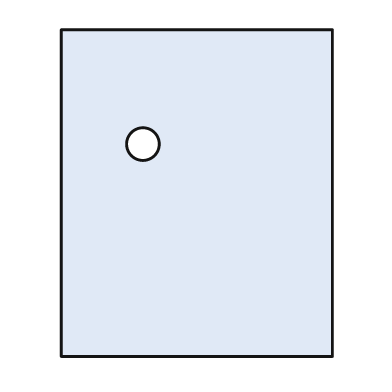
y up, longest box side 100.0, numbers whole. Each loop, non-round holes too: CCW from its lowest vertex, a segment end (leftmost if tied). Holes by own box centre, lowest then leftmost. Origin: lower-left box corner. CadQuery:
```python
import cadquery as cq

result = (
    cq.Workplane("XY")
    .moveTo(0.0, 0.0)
    .lineTo(83.0, 0.0)
    .lineTo(83.0, 100.0)
    .lineTo(0.0, 100.0)
    .close()
    .moveTo(25.0, 65.0)
    .circle(5.0)
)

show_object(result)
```